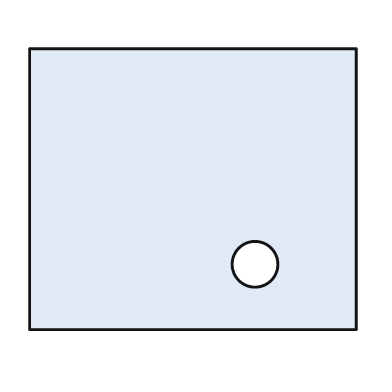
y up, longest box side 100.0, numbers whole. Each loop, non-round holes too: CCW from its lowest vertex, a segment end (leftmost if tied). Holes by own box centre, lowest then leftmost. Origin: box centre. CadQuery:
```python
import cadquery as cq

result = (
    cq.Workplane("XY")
    .moveTo(-50.0, -43.0)
    .lineTo(50.0, -43.0)
    .lineTo(50.0, 43.0)
    .lineTo(-50.0, 43.0)
    .close()
    .moveTo(19.0, -23.0)
    .circle(7.0)
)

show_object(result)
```